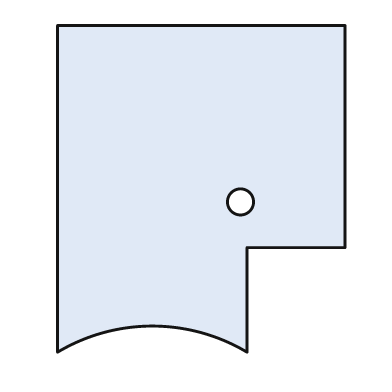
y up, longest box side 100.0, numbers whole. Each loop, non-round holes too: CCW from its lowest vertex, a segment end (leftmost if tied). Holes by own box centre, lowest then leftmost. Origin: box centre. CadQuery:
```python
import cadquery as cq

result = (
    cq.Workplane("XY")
    .moveTo(-44.0, -50.0)
    .threePointArc((-15.0, -42.0), (14.0, -50.0))
    .lineTo(14.0, -18.0)
    .lineTo(44.0, -18.0)
    .lineTo(44.0, 50.0)
    .lineTo(-44.0, 50.0)
    .close()
    .moveTo(12.0, -4.0)
    .circle(4.0)
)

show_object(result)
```